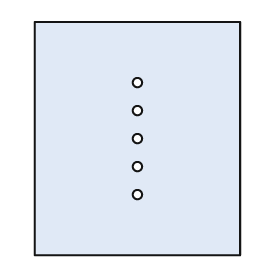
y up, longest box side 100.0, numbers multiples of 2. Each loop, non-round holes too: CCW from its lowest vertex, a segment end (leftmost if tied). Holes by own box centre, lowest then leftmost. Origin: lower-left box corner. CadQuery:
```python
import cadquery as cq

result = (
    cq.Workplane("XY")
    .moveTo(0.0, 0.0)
    .lineTo(88.0, 0.0)
    .lineTo(88.0, 100.0)
    .lineTo(0.0, 100.0)
    .close()
    .moveTo(44.0, 26.0)
    .circle(2.0)
    .moveTo(44.0, 38.0)
    .circle(2.0)
    .moveTo(44.0, 50.0)
    .circle(2.0)
    .moveTo(44.0, 62.0)
    .circle(2.0)
    .moveTo(44.0, 74.0)
    .circle(2.0)
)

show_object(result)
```